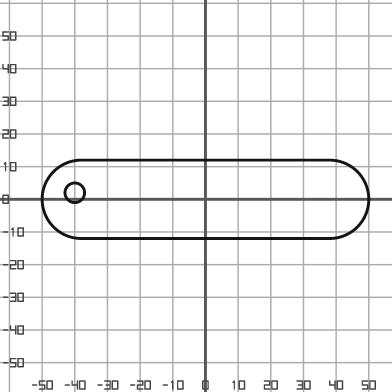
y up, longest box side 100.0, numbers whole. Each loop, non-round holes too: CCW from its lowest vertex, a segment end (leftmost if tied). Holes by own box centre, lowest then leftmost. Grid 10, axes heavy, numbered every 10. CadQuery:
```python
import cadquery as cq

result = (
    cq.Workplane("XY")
    .moveTo(-38.0, -12.0)
    .lineTo(38.0, -12.0)
    .threePointArc((50.0, 0.0), (38.0, 12.0))
    .lineTo(-38.0, 12.0)
    .threePointArc((-50.0, 0.0), (-38.0, -12.0))
    .close()
    .moveTo(-40.0, 2.0)
    .circle(3.0)
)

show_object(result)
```